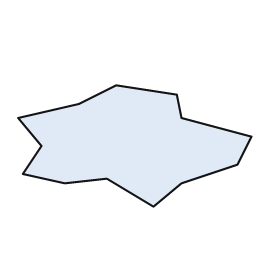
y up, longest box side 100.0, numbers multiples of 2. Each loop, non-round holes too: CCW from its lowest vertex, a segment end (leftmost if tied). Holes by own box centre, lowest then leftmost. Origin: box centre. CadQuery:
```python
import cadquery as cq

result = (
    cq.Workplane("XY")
    .moveTo(8.0, -26.0)
    .lineTo(20.0, -16.0)
    .lineTo(44.0, -8.0)
    .lineTo(50.0, 4.0)
    .lineTo(20.0, 12.0)
    .lineTo(18.0, 22.0)
    .lineTo(-8.0, 26.0)
    .lineTo(-24.0, 18.0)
    .lineTo(-50.0, 12.0)
    .lineTo(-40.0, 0.0)
    .lineTo(-48.0, -12.0)
    .lineTo(-30.0, -16.0)
    .lineTo(-12.0, -14.0)
    .close()
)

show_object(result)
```